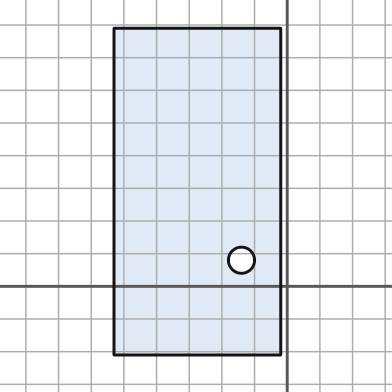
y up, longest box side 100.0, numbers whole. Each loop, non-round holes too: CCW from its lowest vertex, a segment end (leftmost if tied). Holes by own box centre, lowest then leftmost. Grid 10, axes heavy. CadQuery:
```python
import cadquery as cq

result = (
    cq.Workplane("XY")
    .moveTo(-53.0, -21.0)
    .lineTo(-2.0, -21.0)
    .lineTo(-2.0, 79.0)
    .lineTo(-53.0, 79.0)
    .close()
    .moveTo(-14.0, 8.0)
    .circle(4.0)
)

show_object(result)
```